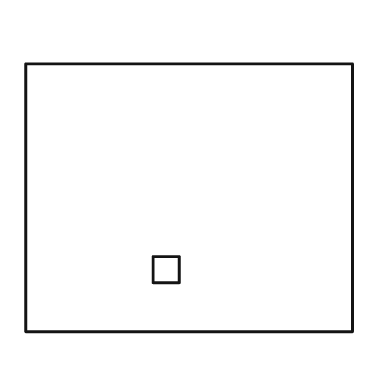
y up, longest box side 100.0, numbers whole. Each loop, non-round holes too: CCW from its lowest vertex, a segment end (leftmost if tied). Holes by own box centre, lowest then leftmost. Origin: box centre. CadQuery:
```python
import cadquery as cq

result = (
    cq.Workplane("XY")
    .moveTo(-50.0, -41.0)
    .lineTo(50.0, -41.0)
    .lineTo(50.0, 41.0)
    .lineTo(-50.0, 41.0)
    .close()
    .moveTo(-11.0, -26.0)
    .lineTo(-3.0, -26.0)
    .lineTo(-3.0, -18.0)
    .lineTo(-11.0, -18.0)
    .close()
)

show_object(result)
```